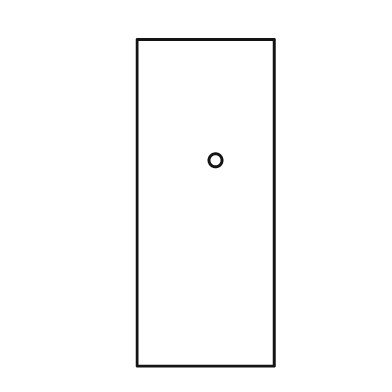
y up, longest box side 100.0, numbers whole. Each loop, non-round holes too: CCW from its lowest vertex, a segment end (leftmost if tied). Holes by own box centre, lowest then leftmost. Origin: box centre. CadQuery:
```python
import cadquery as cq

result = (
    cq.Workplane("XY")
    .moveTo(-21.0, -50.0)
    .lineTo(21.0, -50.0)
    .lineTo(21.0, 50.0)
    .lineTo(-21.0, 50.0)
    .close()
    .moveTo(3.0, 13.0)
    .circle(2.0)
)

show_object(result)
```